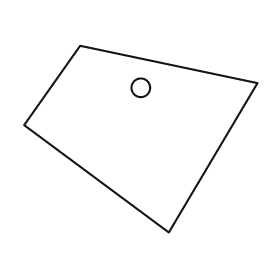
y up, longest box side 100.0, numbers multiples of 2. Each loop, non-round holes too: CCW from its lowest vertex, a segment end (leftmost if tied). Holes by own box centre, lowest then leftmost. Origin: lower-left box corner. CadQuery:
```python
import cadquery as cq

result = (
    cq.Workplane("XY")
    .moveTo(62.0, 0.0)
    .lineTo(100.0, 64.0)
    .lineTo(24.0, 80.0)
    .lineTo(0.0, 46.0)
    .close()
    .moveTo(50.0, 62.0)
    .circle(4.0)
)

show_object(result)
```